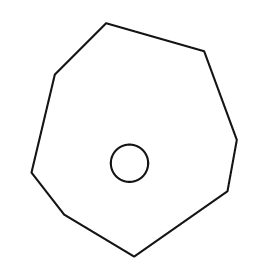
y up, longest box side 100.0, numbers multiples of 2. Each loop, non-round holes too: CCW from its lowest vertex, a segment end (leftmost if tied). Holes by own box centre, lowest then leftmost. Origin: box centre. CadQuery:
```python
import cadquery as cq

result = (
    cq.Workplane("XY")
    .moveTo(0.0, -50.0)
    .lineTo(40.0, -22.0)
    .lineTo(44.0, 0.0)
    .lineTo(30.0, 38.0)
    .lineTo(-12.0, 50.0)
    .lineTo(-34.0, 28.0)
    .lineTo(-44.0, -14.0)
    .lineTo(-30.0, -32.0)
    .close()
    .moveTo(-2.0, -10.0)
    .circle(8.0)
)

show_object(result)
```